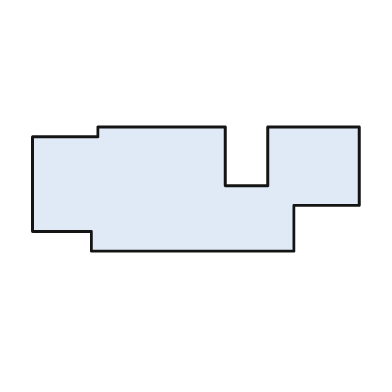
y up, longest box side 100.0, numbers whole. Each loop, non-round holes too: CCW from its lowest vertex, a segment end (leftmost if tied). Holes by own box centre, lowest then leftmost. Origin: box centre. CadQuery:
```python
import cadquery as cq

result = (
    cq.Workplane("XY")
    .moveTo(-32.0, -19.0)
    .lineTo(30.0, -19.0)
    .lineTo(30.0, -5.0)
    .lineTo(50.0, -5.0)
    .lineTo(50.0, 19.0)
    .lineTo(22.0, 19.0)
    .lineTo(22.0, 1.0)
    .lineTo(9.0, 1.0)
    .lineTo(9.0, 19.0)
    .lineTo(-30.0, 19.0)
    .lineTo(-30.0, 16.0)
    .lineTo(-50.0, 16.0)
    .lineTo(-50.0, -13.0)
    .lineTo(-32.0, -13.0)
    .close()
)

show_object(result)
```